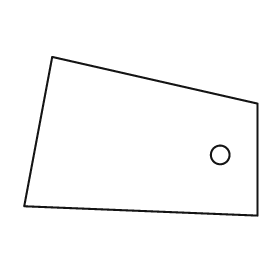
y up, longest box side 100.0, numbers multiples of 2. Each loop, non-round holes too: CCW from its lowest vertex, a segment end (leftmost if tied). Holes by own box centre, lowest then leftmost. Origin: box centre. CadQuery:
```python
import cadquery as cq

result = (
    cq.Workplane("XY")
    .moveTo(50.0, -34.0)
    .lineTo(50.0, 14.0)
    .lineTo(-38.0, 34.0)
    .lineTo(-50.0, -30.0)
    .close()
    .moveTo(34.0, -8.0)
    .circle(4.0)
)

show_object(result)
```